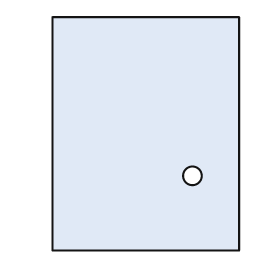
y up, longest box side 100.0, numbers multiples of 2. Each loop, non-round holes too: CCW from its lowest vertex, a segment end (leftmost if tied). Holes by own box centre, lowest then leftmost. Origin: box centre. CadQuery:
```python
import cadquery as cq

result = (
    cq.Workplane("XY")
    .moveTo(-40.0, -50.0)
    .lineTo(40.0, -50.0)
    .lineTo(40.0, 50.0)
    .lineTo(-40.0, 50.0)
    .close()
    .moveTo(20.0, -18.0)
    .circle(4.0)
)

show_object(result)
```